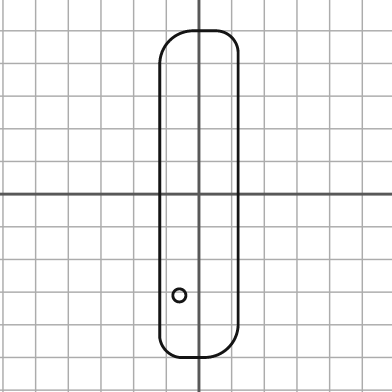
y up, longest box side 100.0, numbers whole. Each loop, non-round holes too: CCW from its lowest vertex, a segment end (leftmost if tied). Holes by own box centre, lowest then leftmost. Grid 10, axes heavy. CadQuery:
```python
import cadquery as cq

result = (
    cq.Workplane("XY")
    .moveTo(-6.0, -50.0)
    .lineTo(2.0, -50.0)
    .threePointArc((9.0, -47.0), (12.0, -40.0))
    .lineTo(12.0, 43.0)
    .threePointArc((10.0, 48.0), (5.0, 50.0))
    .lineTo(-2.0, 50.0)
    .threePointArc((-9.0, 47.0), (-12.0, 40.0))
    .lineTo(-12.0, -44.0)
    .threePointArc((-10.0, -48.0), (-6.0, -50.0))
    .close()
    .moveTo(-6.0, -31.0)
    .circle(2.0)
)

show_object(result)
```